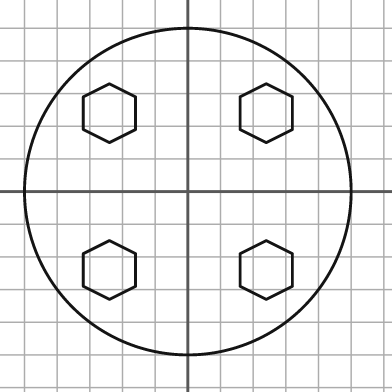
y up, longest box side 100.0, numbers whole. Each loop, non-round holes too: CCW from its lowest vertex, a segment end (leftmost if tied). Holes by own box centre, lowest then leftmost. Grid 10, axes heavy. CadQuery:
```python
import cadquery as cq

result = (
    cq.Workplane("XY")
    .moveTo(0.0, 0.0)
    .circle(50.0)
    .moveTo(-24.0, -33.0)
    .lineTo(-16.0, -29.0)
    .lineTo(-16.0, -19.0)
    .lineTo(-24.0, -15.0)
    .lineTo(-32.0, -19.0)
    .lineTo(-32.0, -29.0)
    .close()
    .moveTo(24.0, -33.0)
    .lineTo(32.0, -29.0)
    .lineTo(32.0, -19.0)
    .lineTo(24.0, -15.0)
    .lineTo(16.0, -19.0)
    .lineTo(16.0, -29.0)
    .close()
    .moveTo(-24.0, 15.0)
    .lineTo(-16.0, 19.0)
    .lineTo(-16.0, 29.0)
    .lineTo(-24.0, 33.0)
    .lineTo(-32.0, 29.0)
    .lineTo(-32.0, 19.0)
    .close()
    .moveTo(24.0, 15.0)
    .lineTo(32.0, 19.0)
    .lineTo(32.0, 29.0)
    .lineTo(24.0, 33.0)
    .lineTo(16.0, 29.0)
    .lineTo(16.0, 19.0)
    .close()
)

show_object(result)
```